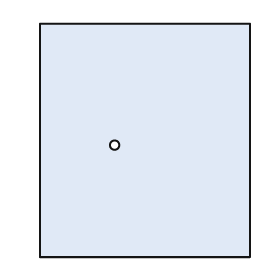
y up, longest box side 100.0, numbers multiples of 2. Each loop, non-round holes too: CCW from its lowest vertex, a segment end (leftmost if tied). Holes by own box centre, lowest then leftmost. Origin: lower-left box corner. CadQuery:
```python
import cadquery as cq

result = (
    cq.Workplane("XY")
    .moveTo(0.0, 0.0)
    .lineTo(90.0, 0.0)
    .lineTo(90.0, 100.0)
    .lineTo(0.0, 100.0)
    .close()
    .moveTo(32.0, 48.0)
    .circle(2.0)
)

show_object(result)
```